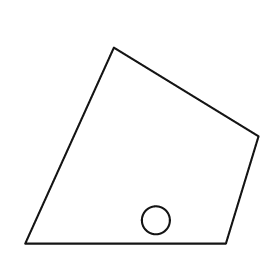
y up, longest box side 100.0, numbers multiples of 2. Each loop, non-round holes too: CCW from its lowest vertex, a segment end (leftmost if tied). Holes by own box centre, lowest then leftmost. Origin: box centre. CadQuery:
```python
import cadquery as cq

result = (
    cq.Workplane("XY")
    .moveTo(-50.0, -42.0)
    .lineTo(36.0, -42.0)
    .lineTo(50.0, 4.0)
    .lineTo(-12.0, 42.0)
    .close()
    .moveTo(6.0, -32.0)
    .circle(6.0)
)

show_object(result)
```